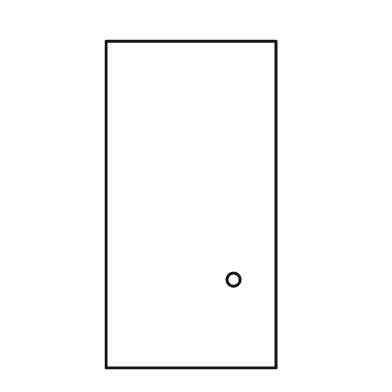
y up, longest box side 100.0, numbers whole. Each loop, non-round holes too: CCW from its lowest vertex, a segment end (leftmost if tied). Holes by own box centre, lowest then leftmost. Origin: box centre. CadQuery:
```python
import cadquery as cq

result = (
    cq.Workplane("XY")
    .moveTo(-26.0, -50.0)
    .lineTo(26.0, -50.0)
    .lineTo(26.0, 50.0)
    .lineTo(-26.0, 50.0)
    .close()
    .moveTo(13.0, -23.0)
    .circle(2.0)
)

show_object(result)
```